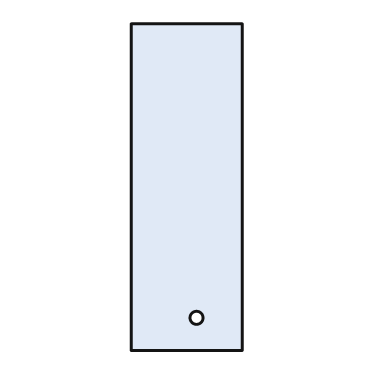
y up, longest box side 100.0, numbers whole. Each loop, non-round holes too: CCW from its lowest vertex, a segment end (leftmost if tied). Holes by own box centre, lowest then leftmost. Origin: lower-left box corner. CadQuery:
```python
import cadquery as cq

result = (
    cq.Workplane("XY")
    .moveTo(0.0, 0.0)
    .lineTo(34.0, 0.0)
    .lineTo(34.0, 100.0)
    .lineTo(0.0, 100.0)
    .close()
    .moveTo(20.0, 10.0)
    .circle(2.0)
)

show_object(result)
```